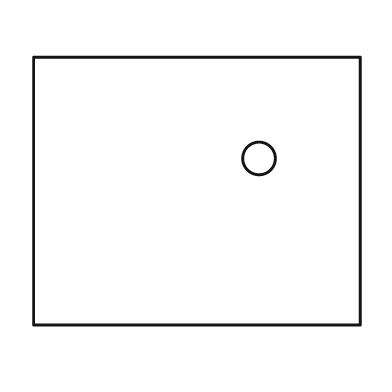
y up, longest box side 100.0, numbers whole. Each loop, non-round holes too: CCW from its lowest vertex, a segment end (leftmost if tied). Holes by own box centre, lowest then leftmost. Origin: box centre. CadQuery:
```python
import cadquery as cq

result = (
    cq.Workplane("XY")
    .moveTo(-50.0, -41.0)
    .lineTo(50.0, -41.0)
    .lineTo(50.0, 41.0)
    .lineTo(-50.0, 41.0)
    .close()
    .moveTo(19.0, 10.0)
    .circle(5.0)
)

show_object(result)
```